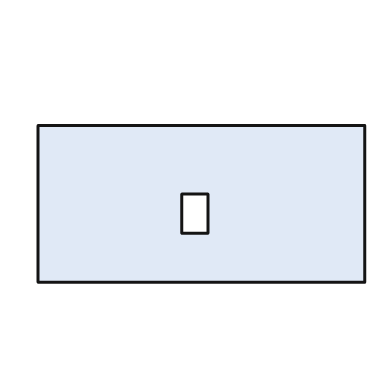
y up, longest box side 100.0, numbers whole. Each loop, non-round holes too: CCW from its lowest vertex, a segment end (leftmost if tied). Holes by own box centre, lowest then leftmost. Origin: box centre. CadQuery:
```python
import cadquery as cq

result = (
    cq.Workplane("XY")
    .moveTo(-50.0, -24.0)
    .lineTo(50.0, -24.0)
    .lineTo(50.0, 24.0)
    .lineTo(-50.0, 24.0)
    .close()
    .moveTo(-6.0, -9.0)
    .lineTo(2.0, -9.0)
    .lineTo(2.0, 3.0)
    .lineTo(-6.0, 3.0)
    .close()
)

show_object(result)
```